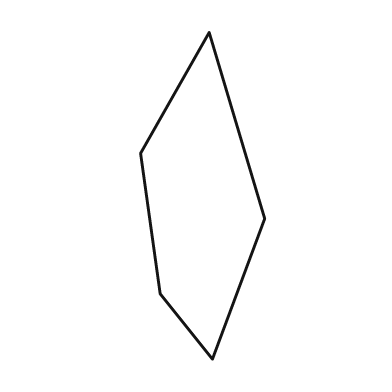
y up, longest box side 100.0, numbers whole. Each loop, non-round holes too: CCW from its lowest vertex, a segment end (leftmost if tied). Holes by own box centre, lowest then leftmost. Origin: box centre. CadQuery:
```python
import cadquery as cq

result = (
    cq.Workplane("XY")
    .moveTo(3.0, -50.0)
    .lineTo(19.0, -7.0)
    .lineTo(2.0, 50.0)
    .lineTo(-19.0, 13.0)
    .lineTo(-13.0, -30.0)
    .close()
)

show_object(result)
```